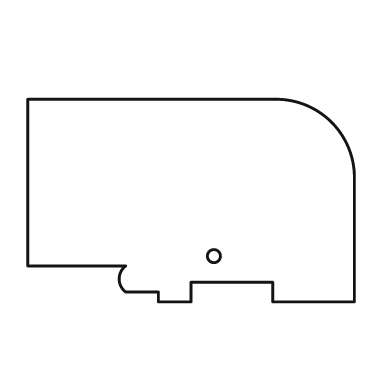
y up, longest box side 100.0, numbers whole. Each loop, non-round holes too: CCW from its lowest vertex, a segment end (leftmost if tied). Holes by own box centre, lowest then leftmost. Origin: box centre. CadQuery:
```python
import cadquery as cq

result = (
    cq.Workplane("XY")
    .moveTo(-10.0, -31.0)
    .lineTo(0.0, -31.0)
    .lineTo(0.0, -25.0)
    .lineTo(25.0, -25.0)
    .lineTo(25.0, -31.0)
    .lineTo(50.0, -31.0)
    .lineTo(50.0, 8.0)
    .threePointArc((43.0, 24.0), (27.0, 31.0))
    .lineTo(-50.0, 31.0)
    .lineTo(-50.0, -20.0)
    .lineTo(-20.0, -20.0)
    .threePointArc((-22.0, -24.0), (-20.0, -28.0))
    .lineTo(-10.0, -28.0)
    .close()
    .moveTo(7.0, -17.0)
    .circle(2.0)
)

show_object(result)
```